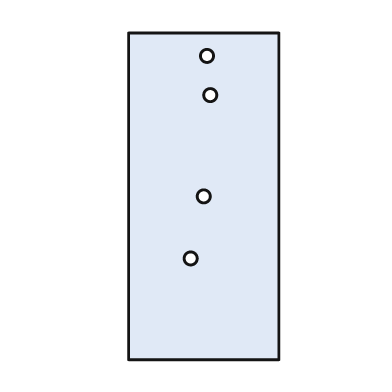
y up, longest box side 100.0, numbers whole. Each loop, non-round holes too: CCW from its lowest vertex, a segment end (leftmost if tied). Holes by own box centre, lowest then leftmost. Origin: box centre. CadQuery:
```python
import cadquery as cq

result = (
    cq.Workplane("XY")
    .moveTo(-23.0, -50.0)
    .lineTo(23.0, -50.0)
    .lineTo(23.0, 50.0)
    .lineTo(-23.0, 50.0)
    .close()
    .moveTo(-4.0, -19.0)
    .circle(2.0)
    .moveTo(0.0, 0.0)
    .circle(2.0)
    .moveTo(2.0, 31.0)
    .circle(2.0)
    .moveTo(1.0, 43.0)
    .circle(2.0)
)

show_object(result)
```